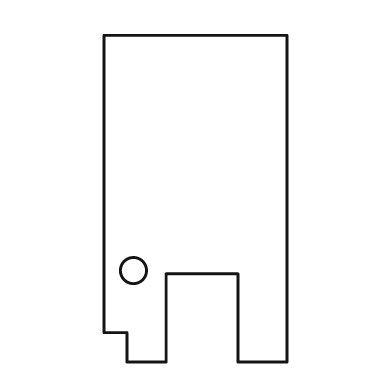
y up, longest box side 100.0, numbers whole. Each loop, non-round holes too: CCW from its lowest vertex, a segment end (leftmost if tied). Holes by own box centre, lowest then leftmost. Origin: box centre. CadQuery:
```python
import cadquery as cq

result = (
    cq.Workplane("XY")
    .moveTo(-21.0, -50.0)
    .lineTo(-9.0, -50.0)
    .lineTo(-9.0, -23.0)
    .lineTo(13.0, -23.0)
    .lineTo(13.0, -50.0)
    .lineTo(28.0, -50.0)
    .lineTo(28.0, 50.0)
    .lineTo(-28.0, 50.0)
    .lineTo(-28.0, -41.0)
    .lineTo(-21.0, -41.0)
    .close()
    .moveTo(-19.0, -22.0)
    .circle(4.0)
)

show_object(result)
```